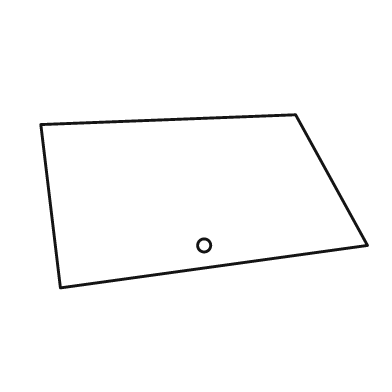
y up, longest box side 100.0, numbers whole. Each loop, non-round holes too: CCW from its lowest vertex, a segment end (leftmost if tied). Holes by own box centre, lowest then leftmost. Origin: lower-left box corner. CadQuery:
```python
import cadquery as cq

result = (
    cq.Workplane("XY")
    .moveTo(6.0, 0.0)
    .lineTo(100.0, 13.0)
    .lineTo(78.0, 53.0)
    .lineTo(0.0, 50.0)
    .close()
    .moveTo(50.0, 13.0)
    .circle(2.0)
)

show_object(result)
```